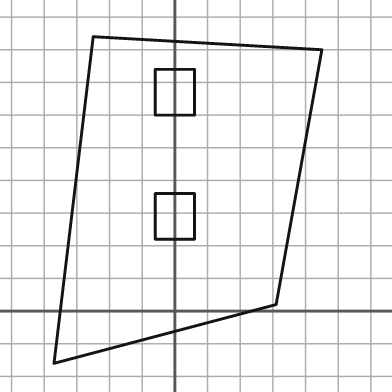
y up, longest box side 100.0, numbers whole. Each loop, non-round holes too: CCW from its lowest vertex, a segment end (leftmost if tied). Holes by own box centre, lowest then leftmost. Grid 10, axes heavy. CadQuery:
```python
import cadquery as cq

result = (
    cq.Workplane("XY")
    .moveTo(-37.0, -16.0)
    .lineTo(31.0, 2.0)
    .lineTo(45.0, 80.0)
    .lineTo(-25.0, 84.0)
    .close()
    .moveTo(-6.0, 22.0)
    .lineTo(6.0, 22.0)
    .lineTo(6.0, 36.0)
    .lineTo(-6.0, 36.0)
    .close()
    .moveTo(-6.0, 60.0)
    .lineTo(6.0, 60.0)
    .lineTo(6.0, 74.0)
    .lineTo(-6.0, 74.0)
    .close()
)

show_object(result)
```